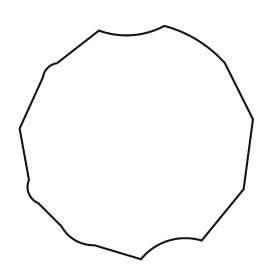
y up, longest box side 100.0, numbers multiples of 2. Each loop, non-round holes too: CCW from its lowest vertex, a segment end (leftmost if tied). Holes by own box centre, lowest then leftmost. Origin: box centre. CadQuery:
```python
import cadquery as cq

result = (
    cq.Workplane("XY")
    .moveTo(2.0, -50.0)
    .threePointArc((14.0, -42.0), (28.0, -42.0))
    .lineTo(46.0, -20.0)
    .lineTo(50.0, 10.0)
    .lineTo(38.0, 34.0)
    .threePointArc((26.0, 44.0), (12.0, 50.0))
    .threePointArc((-2.0, 46.0), (-16.0, 48.0))
    .lineTo(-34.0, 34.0)
    .threePointArc((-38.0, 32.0), (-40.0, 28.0))
    .lineTo(-50.0, 6.0)
    .lineTo(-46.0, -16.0)
    .threePointArc((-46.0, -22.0), (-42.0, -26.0))
    .lineTo(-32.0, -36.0)
    .threePointArc((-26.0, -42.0), (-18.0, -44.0))
    .close()
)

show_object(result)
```